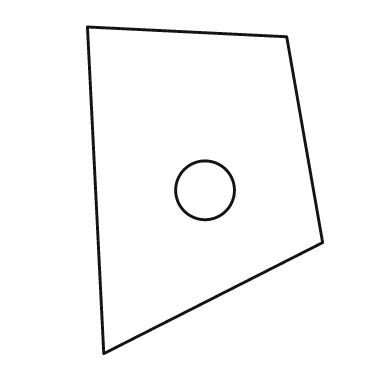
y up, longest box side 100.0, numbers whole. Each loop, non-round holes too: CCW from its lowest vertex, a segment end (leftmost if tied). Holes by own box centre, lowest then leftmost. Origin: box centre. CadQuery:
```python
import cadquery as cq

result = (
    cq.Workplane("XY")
    .moveTo(-31.0, -50.0)
    .lineTo(36.0, -16.0)
    .lineTo(25.0, 47.0)
    .lineTo(-36.0, 50.0)
    .close()
    .moveTo(0.0, 0.0)
    .circle(9.0)
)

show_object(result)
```